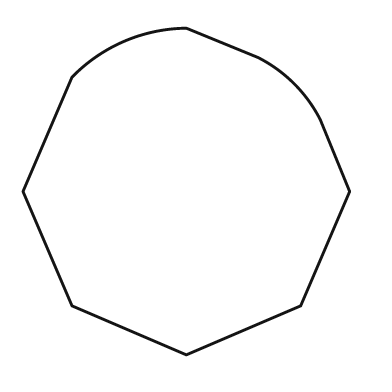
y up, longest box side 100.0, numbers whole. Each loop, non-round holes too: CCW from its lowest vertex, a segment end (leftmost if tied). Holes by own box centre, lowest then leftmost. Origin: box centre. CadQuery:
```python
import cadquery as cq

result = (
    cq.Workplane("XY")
    .moveTo(0.0, -50.0)
    .lineTo(35.0, -35.0)
    .lineTo(50.0, 0.0)
    .lineTo(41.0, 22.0)
    .threePointArc((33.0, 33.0), (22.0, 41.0))
    .lineTo(0.0, 50.0)
    .threePointArc((-19.0, 46.0), (-35.0, 35.0))
    .lineTo(-50.0, 0.0)
    .lineTo(-35.0, -35.0)
    .close()
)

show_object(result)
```